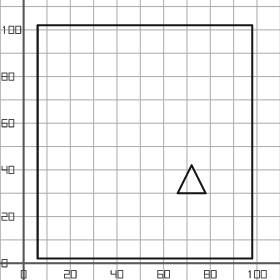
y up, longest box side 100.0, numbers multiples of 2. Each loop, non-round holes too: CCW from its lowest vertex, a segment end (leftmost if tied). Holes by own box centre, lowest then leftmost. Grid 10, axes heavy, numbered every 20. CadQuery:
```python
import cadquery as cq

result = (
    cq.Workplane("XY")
    .moveTo(6.0, 2.0)
    .lineTo(98.0, 2.0)
    .lineTo(98.0, 102.0)
    .lineTo(6.0, 102.0)
    .close()
    .moveTo(66.0, 30.0)
    .lineTo(78.0, 30.0)
    .lineTo(72.0, 42.0)
    .close()
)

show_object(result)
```